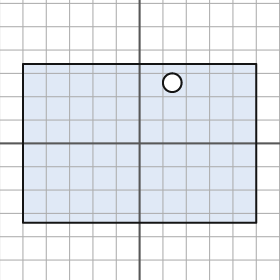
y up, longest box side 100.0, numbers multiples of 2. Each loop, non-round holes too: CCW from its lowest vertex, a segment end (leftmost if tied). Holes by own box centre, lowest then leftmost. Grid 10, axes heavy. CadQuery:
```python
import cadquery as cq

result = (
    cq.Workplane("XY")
    .moveTo(-50.0, -34.0)
    .lineTo(50.0, -34.0)
    .lineTo(50.0, 34.0)
    .lineTo(-50.0, 34.0)
    .close()
    .moveTo(14.0, 26.0)
    .circle(4.0)
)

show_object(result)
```